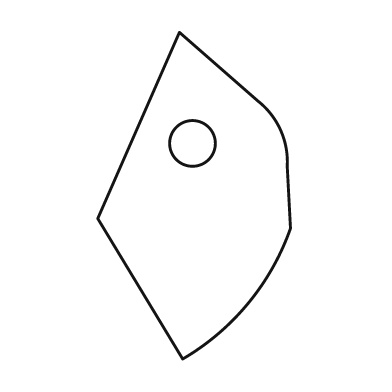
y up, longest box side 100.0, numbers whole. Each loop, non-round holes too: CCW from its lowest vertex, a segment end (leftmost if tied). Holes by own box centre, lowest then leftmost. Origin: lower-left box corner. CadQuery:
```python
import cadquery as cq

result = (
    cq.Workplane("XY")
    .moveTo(26.0, 0.0)
    .threePointArc((46.0, 17.0), (59.0, 40.0))
    .lineTo(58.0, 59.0)
    .threePointArc((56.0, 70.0), (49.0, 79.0))
    .lineTo(25.0, 100.0)
    .lineTo(0.0, 43.0)
    .close()
    .moveTo(29.0, 66.0)
    .circle(7.0)
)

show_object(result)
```